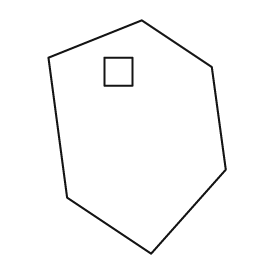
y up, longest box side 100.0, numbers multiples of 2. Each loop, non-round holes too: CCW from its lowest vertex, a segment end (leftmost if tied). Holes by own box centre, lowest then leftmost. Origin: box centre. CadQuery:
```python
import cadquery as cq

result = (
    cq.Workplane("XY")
    .moveTo(6.0, -50.0)
    .lineTo(38.0, -14.0)
    .lineTo(32.0, 30.0)
    .lineTo(2.0, 50.0)
    .lineTo(-38.0, 34.0)
    .lineTo(-30.0, -26.0)
    .close()
    .moveTo(-14.0, 22.0)
    .lineTo(-2.0, 22.0)
    .lineTo(-2.0, 34.0)
    .lineTo(-14.0, 34.0)
    .close()
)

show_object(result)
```